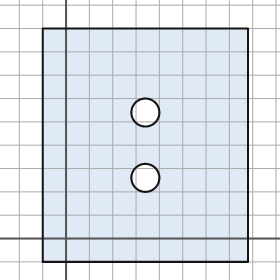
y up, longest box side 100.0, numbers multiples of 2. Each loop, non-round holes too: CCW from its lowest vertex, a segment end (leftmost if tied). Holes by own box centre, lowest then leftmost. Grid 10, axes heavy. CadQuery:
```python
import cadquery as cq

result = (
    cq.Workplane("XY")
    .moveTo(-10.0, -10.0)
    .lineTo(78.0, -10.0)
    .lineTo(78.0, 90.0)
    .lineTo(-10.0, 90.0)
    .close()
    .moveTo(34.0, 26.0)
    .circle(6.0)
    .moveTo(34.0, 54.0)
    .circle(6.0)
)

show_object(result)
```